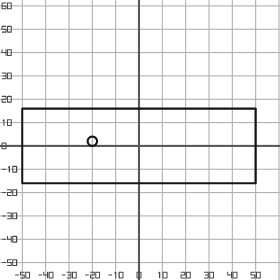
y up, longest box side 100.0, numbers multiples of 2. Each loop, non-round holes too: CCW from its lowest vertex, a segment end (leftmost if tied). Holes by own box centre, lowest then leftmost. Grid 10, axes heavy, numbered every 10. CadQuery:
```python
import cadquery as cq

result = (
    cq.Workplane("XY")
    .moveTo(-50.0, -16.0)
    .lineTo(50.0, -16.0)
    .lineTo(50.0, 16.0)
    .lineTo(-50.0, 16.0)
    .close()
    .moveTo(-20.0, 2.0)
    .circle(2.0)
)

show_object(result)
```